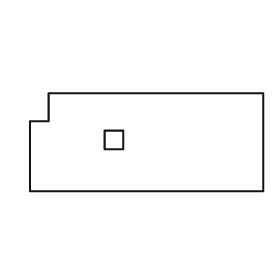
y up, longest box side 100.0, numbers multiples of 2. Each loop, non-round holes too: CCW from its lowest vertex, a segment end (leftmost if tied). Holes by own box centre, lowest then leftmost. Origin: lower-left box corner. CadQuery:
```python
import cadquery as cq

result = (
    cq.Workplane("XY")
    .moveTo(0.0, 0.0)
    .lineTo(100.0, 0.0)
    .lineTo(100.0, 42.0)
    .lineTo(8.0, 42.0)
    .lineTo(8.0, 30.0)
    .lineTo(0.0, 30.0)
    .close()
    .moveTo(32.0, 18.0)
    .lineTo(40.0, 18.0)
    .lineTo(40.0, 26.0)
    .lineTo(32.0, 26.0)
    .close()
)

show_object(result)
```